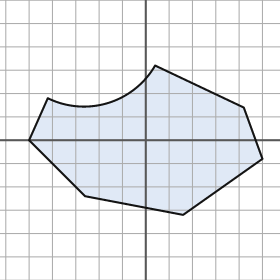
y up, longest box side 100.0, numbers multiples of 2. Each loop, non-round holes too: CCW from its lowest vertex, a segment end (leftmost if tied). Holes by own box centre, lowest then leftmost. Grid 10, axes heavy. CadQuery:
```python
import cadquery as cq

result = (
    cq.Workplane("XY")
    .moveTo(16.0, -32.0)
    .lineTo(50.0, -8.0)
    .lineTo(42.0, 14.0)
    .lineTo(4.0, 32.0)
    .threePointArc((-16.0, 16.0), (-42.0, 18.0))
    .lineTo(-50.0, 0.0)
    .lineTo(-26.0, -24.0)
    .close()
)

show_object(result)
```